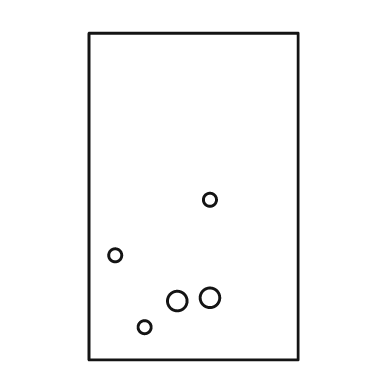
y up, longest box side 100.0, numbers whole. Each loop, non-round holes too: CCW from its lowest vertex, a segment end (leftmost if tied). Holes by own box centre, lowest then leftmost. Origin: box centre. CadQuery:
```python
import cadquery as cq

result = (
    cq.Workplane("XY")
    .moveTo(-32.0, -50.0)
    .lineTo(32.0, -50.0)
    .lineTo(32.0, 50.0)
    .lineTo(-32.0, 50.0)
    .close()
    .moveTo(-15.0, -40.0)
    .circle(2.0)
    .moveTo(-5.0, -32.0)
    .circle(3.0)
    .moveTo(5.0, -31.0)
    .circle(3.0)
    .moveTo(-24.0, -18.0)
    .circle(2.0)
    .moveTo(5.0, -1.0)
    .circle(2.0)
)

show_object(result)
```